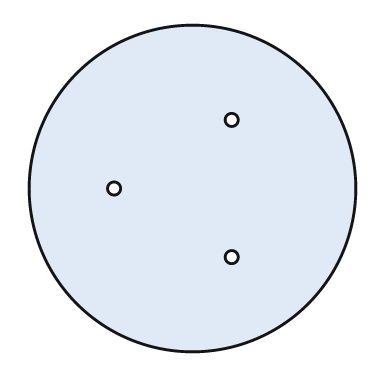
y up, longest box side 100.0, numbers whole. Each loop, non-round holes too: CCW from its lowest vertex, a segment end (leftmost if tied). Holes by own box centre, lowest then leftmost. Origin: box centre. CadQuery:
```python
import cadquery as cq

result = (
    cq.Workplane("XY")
    .moveTo(0.0, 0.0)
    .circle(50.0)
    .moveTo(12.0, -21.0)
    .circle(2.0)
    .moveTo(-24.0, 0.0)
    .circle(2.0)
    .moveTo(12.0, 21.0)
    .circle(2.0)
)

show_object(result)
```